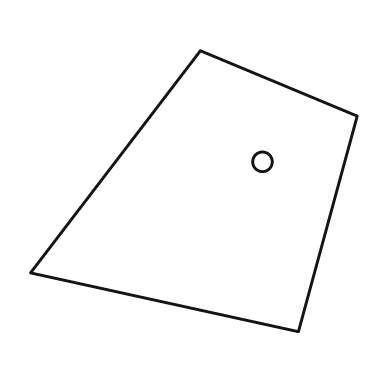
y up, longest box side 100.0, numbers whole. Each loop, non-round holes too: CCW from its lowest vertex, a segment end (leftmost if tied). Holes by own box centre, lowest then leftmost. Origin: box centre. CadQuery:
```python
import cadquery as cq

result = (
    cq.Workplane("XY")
    .moveTo(32.0, -43.0)
    .lineTo(50.0, 23.0)
    .lineTo(2.0, 43.0)
    .lineTo(-50.0, -25.0)
    .close()
    .moveTo(21.0, 9.0)
    .circle(3.0)
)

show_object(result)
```